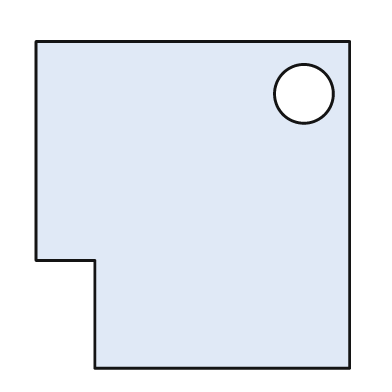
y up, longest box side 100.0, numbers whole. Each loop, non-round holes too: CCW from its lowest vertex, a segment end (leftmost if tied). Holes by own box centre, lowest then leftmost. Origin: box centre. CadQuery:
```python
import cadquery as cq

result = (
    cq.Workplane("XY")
    .moveTo(-30.0, -50.0)
    .lineTo(48.0, -50.0)
    .lineTo(48.0, 50.0)
    .lineTo(-48.0, 50.0)
    .lineTo(-48.0, -17.0)
    .lineTo(-30.0, -17.0)
    .close()
    .moveTo(34.0, 34.0)
    .circle(9.0)
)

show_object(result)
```